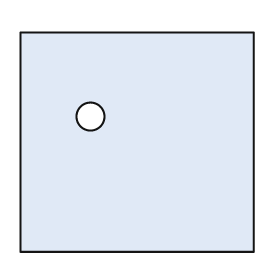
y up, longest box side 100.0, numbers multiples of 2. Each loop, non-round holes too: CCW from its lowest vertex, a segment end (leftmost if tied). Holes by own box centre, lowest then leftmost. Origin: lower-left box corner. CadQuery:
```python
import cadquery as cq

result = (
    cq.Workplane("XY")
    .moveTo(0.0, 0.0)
    .lineTo(100.0, 0.0)
    .lineTo(100.0, 94.0)
    .lineTo(0.0, 94.0)
    .close()
    .moveTo(30.0, 58.0)
    .circle(6.0)
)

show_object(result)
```